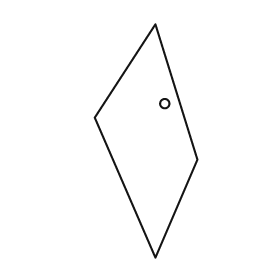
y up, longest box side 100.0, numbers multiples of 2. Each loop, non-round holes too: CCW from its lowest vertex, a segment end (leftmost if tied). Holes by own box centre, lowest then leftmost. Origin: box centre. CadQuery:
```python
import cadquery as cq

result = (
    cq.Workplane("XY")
    .moveTo(4.0, -50.0)
    .lineTo(22.0, -8.0)
    .lineTo(4.0, 50.0)
    .lineTo(-22.0, 10.0)
    .close()
    .moveTo(8.0, 16.0)
    .circle(2.0)
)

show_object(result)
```